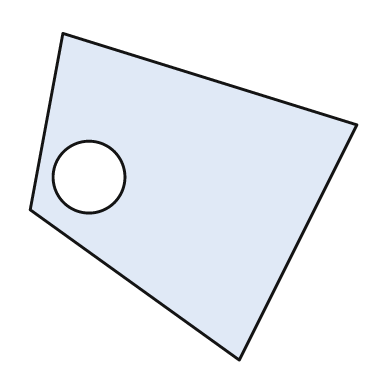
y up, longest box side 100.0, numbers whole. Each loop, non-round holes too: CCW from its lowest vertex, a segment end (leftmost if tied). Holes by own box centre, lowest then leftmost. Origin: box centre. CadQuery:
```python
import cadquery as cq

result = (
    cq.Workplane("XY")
    .moveTo(14.0, -50.0)
    .lineTo(50.0, 22.0)
    .lineTo(-40.0, 50.0)
    .lineTo(-50.0, -4.0)
    .close()
    .moveTo(-32.0, 6.0)
    .circle(11.0)
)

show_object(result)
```